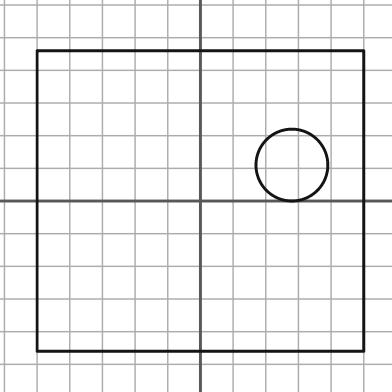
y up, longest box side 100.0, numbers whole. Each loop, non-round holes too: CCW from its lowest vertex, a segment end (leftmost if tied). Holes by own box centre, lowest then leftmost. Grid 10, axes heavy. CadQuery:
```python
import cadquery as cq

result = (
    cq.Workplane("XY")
    .moveTo(-50.0, -46.0)
    .lineTo(50.0, -46.0)
    .lineTo(50.0, 46.0)
    .lineTo(-50.0, 46.0)
    .close()
    .moveTo(28.0, 11.0)
    .circle(11.0)
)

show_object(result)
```